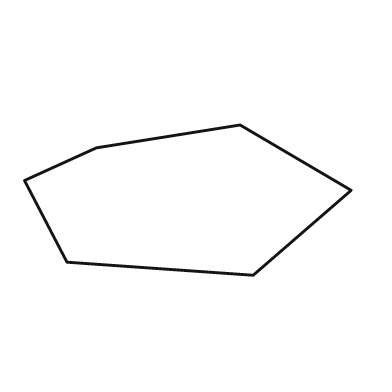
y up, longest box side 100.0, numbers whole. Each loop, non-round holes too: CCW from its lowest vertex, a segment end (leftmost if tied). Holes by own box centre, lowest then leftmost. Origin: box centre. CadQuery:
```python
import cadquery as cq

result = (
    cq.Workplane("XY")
    .moveTo(20.0, -23.0)
    .lineTo(50.0, 3.0)
    .lineTo(16.0, 23.0)
    .lineTo(-28.0, 16.0)
    .lineTo(-50.0, 6.0)
    .lineTo(-37.0, -19.0)
    .close()
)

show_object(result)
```